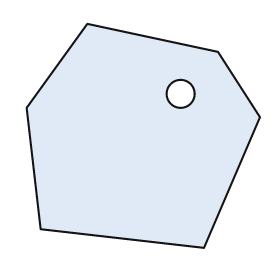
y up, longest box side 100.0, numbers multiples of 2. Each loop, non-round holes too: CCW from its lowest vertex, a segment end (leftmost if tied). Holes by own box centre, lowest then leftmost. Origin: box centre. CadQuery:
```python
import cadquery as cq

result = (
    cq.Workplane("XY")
    .moveTo(26.0, -48.0)
    .lineTo(50.0, 8.0)
    .lineTo(32.0, 36.0)
    .lineTo(-24.0, 48.0)
    .lineTo(-50.0, 12.0)
    .lineTo(-44.0, -40.0)
    .close()
    .moveTo(16.0, 18.0)
    .circle(6.0)
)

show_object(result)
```